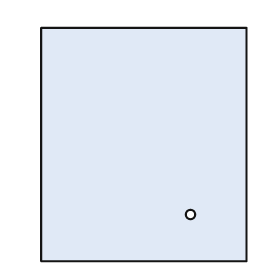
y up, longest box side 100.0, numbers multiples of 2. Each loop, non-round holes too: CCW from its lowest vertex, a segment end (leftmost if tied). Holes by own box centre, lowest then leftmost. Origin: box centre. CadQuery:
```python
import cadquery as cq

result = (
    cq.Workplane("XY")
    .moveTo(-44.0, -50.0)
    .lineTo(44.0, -50.0)
    .lineTo(44.0, 50.0)
    .lineTo(-44.0, 50.0)
    .close()
    .moveTo(20.0, -30.0)
    .circle(2.0)
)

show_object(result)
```